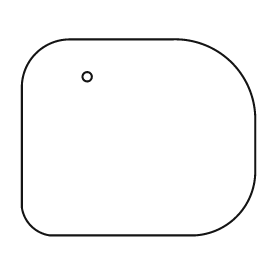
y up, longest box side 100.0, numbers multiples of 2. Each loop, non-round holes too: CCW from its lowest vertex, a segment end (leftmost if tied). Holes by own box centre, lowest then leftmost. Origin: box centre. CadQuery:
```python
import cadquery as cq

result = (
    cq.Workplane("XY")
    .moveTo(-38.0, -42.0)
    .lineTo(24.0, -42.0)
    .threePointArc((42.0, -34.0), (50.0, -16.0))
    .lineTo(50.0, 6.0)
    .threePointArc((40.0, 32.0), (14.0, 42.0))
    .lineTo(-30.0, 42.0)
    .threePointArc((-44.0, 36.0), (-50.0, 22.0))
    .lineTo(-50.0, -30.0)
    .threePointArc((-46.0, -38.0), (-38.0, -42.0))
    .close()
    .moveTo(-22.0, 26.0)
    .circle(2.0)
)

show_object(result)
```